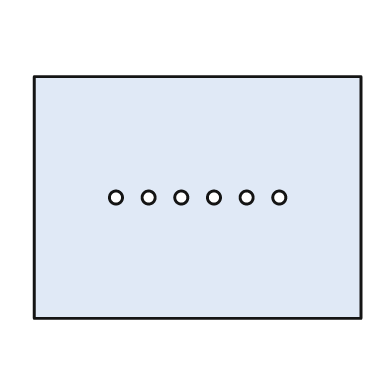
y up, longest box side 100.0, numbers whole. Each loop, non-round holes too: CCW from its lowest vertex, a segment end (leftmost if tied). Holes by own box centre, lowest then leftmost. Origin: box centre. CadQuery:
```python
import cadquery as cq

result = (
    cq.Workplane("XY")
    .moveTo(-50.0, -37.0)
    .lineTo(50.0, -37.0)
    .lineTo(50.0, 37.0)
    .lineTo(-50.0, 37.0)
    .close()
    .moveTo(-25.0, 0.0)
    .circle(2.0)
    .moveTo(-15.0, 0.0)
    .circle(2.0)
    .moveTo(-5.0, 0.0)
    .circle(2.0)
    .moveTo(5.0, 0.0)
    .circle(2.0)
    .moveTo(15.0, 0.0)
    .circle(2.0)
    .moveTo(25.0, 0.0)
    .circle(2.0)
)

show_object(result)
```